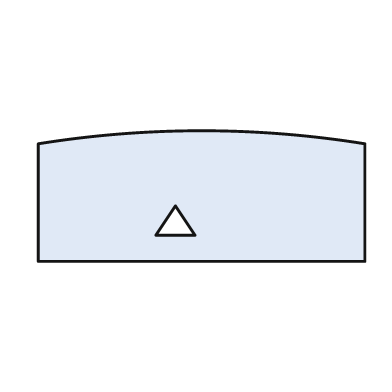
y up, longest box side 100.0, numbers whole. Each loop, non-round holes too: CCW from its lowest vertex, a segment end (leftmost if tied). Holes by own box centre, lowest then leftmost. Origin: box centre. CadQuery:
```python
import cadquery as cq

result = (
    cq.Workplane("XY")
    .moveTo(-50.0, -20.0)
    .lineTo(50.0, -20.0)
    .lineTo(50.0, 16.0)
    .threePointArc((0.0, 20.0), (-50.0, 16.0))
    .close()
    .moveTo(-14.0, -12.0)
    .lineTo(-2.0, -12.0)
    .lineTo(-8.0, -3.0)
    .close()
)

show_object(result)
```